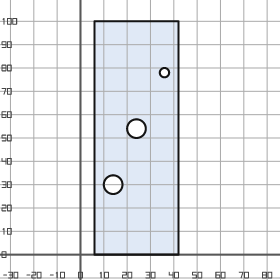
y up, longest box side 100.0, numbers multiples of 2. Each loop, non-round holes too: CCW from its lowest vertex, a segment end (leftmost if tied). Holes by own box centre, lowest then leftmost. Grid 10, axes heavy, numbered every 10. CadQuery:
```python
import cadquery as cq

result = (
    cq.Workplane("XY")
    .moveTo(6.0, 0.0)
    .lineTo(42.0, 0.0)
    .lineTo(42.0, 100.0)
    .lineTo(6.0, 100.0)
    .close()
    .moveTo(14.0, 30.0)
    .circle(4.0)
    .moveTo(24.0, 54.0)
    .circle(4.0)
    .moveTo(36.0, 78.0)
    .circle(2.0)
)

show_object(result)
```